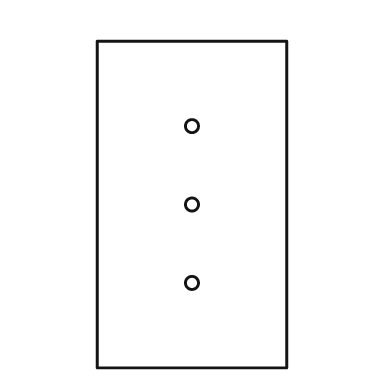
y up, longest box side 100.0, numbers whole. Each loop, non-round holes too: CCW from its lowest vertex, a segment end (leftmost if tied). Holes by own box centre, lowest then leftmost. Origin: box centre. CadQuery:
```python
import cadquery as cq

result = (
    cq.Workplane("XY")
    .moveTo(-29.0, -50.0)
    .lineTo(29.0, -50.0)
    .lineTo(29.0, 50.0)
    .lineTo(-29.0, 50.0)
    .close()
    .moveTo(0.0, -24.0)
    .circle(2.0)
    .moveTo(0.0, 0.0)
    .circle(2.0)
    .moveTo(0.0, 24.0)
    .circle(2.0)
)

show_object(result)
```